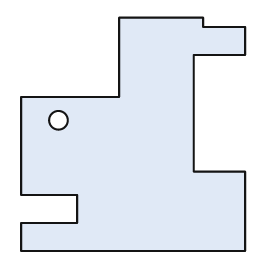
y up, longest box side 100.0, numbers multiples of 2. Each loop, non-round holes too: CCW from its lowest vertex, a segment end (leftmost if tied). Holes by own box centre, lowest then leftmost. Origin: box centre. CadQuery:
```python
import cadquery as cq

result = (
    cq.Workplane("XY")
    .moveTo(-48.0, -50.0)
    .lineTo(48.0, -50.0)
    .lineTo(48.0, -16.0)
    .lineTo(26.0, -16.0)
    .lineTo(26.0, 34.0)
    .lineTo(48.0, 34.0)
    .lineTo(48.0, 46.0)
    .lineTo(30.0, 46.0)
    .lineTo(30.0, 50.0)
    .lineTo(-6.0, 50.0)
    .lineTo(-6.0, 16.0)
    .lineTo(-48.0, 16.0)
    .lineTo(-48.0, -26.0)
    .lineTo(-24.0, -26.0)
    .lineTo(-24.0, -38.0)
    .lineTo(-48.0, -38.0)
    .close()
    .moveTo(-32.0, 6.0)
    .circle(4.0)
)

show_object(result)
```